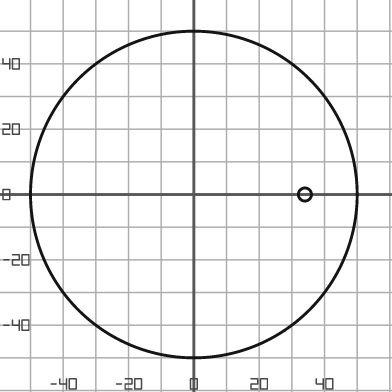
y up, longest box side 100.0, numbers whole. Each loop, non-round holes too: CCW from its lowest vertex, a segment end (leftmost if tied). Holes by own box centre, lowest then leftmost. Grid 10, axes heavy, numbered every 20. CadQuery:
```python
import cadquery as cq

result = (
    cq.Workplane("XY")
    .moveTo(0.0, 0.0)
    .circle(50.0)
    .moveTo(34.0, 0.0)
    .circle(2.0)
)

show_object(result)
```